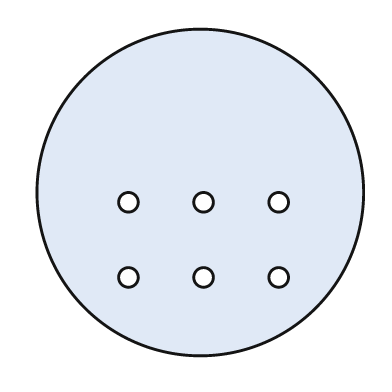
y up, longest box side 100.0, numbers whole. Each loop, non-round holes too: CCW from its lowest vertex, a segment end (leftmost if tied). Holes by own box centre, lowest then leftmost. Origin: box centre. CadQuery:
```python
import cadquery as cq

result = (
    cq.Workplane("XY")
    .moveTo(0.0, 0.0)
    .circle(50.0)
    .moveTo(-22.0, -26.0)
    .circle(3.0)
    .moveTo(1.0, -26.0)
    .circle(3.0)
    .moveTo(24.0, -26.0)
    .circle(3.0)
    .moveTo(-22.0, -3.0)
    .circle(3.0)
    .moveTo(1.0, -3.0)
    .circle(3.0)
    .moveTo(24.0, -3.0)
    .circle(3.0)
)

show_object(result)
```